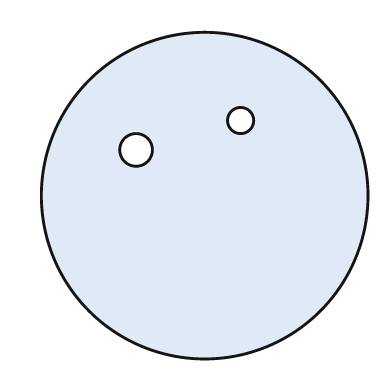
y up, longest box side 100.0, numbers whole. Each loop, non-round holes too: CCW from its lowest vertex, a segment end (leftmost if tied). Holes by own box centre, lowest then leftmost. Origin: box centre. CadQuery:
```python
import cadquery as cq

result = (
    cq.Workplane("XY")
    .moveTo(0.0, 0.0)
    .circle(50.0)
    .moveTo(-21.0, 14.0)
    .circle(5.0)
    .moveTo(11.0, 23.0)
    .circle(4.0)
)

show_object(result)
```